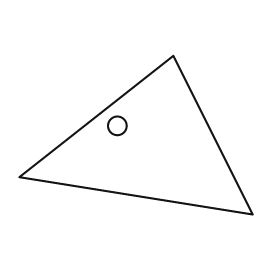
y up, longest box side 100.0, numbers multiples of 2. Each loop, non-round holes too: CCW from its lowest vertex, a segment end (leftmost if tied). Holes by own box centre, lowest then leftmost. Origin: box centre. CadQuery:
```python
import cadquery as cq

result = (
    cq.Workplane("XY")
    .moveTo(50.0, -34.0)
    .lineTo(16.0, 34.0)
    .lineTo(-50.0, -18.0)
    .close()
    .moveTo(-8.0, 4.0)
    .circle(4.0)
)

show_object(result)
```